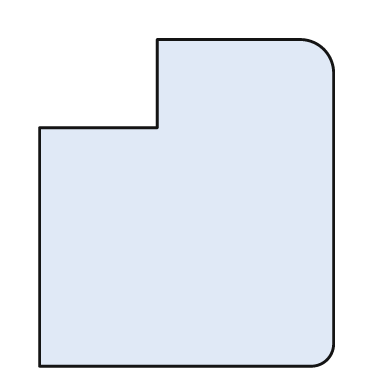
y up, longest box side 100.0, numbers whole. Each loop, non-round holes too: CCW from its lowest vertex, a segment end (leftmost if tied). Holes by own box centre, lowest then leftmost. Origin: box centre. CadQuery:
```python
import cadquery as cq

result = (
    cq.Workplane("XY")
    .moveTo(-45.0, -50.0)
    .lineTo(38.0, -50.0)
    .threePointArc((43.0, -48.0), (45.0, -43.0))
    .lineTo(45.0, 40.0)
    .threePointArc((42.0, 47.0), (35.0, 50.0))
    .lineTo(-9.0, 50.0)
    .lineTo(-9.0, 23.0)
    .lineTo(-45.0, 23.0)
    .close()
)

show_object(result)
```